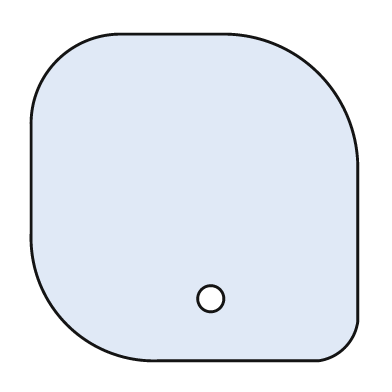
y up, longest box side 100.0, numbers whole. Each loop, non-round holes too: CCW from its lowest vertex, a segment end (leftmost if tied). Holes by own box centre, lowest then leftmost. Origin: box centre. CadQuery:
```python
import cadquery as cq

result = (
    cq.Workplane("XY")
    .moveTo(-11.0, -50.0)
    .lineTo(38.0, -50.0)
    .threePointArc((46.0, -46.0), (50.0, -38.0))
    .lineTo(50.0, 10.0)
    .threePointArc((38.0, 38.0), (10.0, 50.0))
    .lineTo(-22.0, 50.0)
    .threePointArc((-42.0, 42.0), (-50.0, 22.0))
    .lineTo(-50.0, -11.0)
    .threePointArc((-39.0, -39.0), (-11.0, -50.0))
    .close()
    .moveTo(5.0, -31.0)
    .circle(4.0)
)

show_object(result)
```